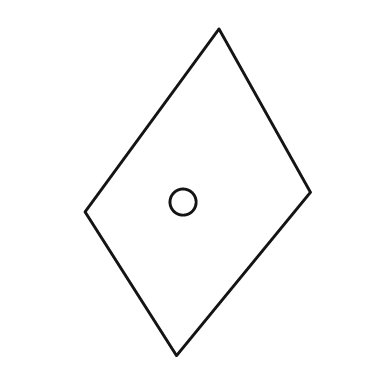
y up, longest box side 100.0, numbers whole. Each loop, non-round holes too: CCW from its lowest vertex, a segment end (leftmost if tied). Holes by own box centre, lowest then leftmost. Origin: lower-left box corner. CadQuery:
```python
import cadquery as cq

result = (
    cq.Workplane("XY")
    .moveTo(28.0, 0.0)
    .lineTo(69.0, 50.0)
    .lineTo(41.0, 100.0)
    .lineTo(0.0, 44.0)
    .close()
    .moveTo(30.0, 47.0)
    .circle(4.0)
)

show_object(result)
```